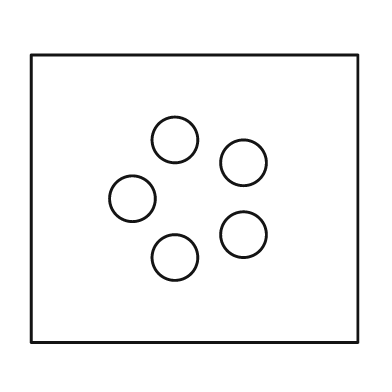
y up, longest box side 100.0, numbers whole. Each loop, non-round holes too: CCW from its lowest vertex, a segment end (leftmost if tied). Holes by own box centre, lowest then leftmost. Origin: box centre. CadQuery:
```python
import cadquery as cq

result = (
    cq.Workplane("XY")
    .moveTo(-50.0, -44.0)
    .lineTo(50.0, -44.0)
    .lineTo(50.0, 44.0)
    .lineTo(-50.0, 44.0)
    .close()
    .moveTo(-6.0, -18.0)
    .circle(7.0)
    .moveTo(15.0, -11.0)
    .circle(7.0)
    .moveTo(-19.0, 0.0)
    .circle(7.0)
    .moveTo(15.0, 11.0)
    .circle(7.0)
    .moveTo(-6.0, 18.0)
    .circle(7.0)
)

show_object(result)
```